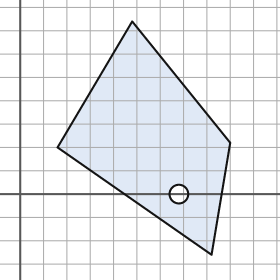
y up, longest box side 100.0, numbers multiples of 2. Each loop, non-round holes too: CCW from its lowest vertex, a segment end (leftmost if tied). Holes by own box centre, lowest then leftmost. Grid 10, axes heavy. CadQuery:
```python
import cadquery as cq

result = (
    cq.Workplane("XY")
    .moveTo(82.0, -26.0)
    .lineTo(90.0, 22.0)
    .lineTo(48.0, 74.0)
    .lineTo(16.0, 20.0)
    .close()
    .moveTo(68.0, 0.0)
    .circle(4.0)
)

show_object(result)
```